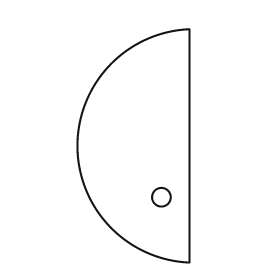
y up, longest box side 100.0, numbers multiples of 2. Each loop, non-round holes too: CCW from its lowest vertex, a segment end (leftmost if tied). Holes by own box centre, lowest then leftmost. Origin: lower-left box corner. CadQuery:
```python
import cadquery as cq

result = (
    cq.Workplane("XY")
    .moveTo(48.0, 0.0)
    .lineTo(48.0, 100.0)
    .threePointArc((0.0, 50.0), (48.0, 0.0))
    .close()
    .moveTo(36.0, 28.0)
    .circle(4.0)
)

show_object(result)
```